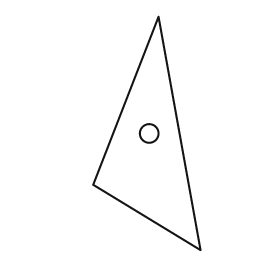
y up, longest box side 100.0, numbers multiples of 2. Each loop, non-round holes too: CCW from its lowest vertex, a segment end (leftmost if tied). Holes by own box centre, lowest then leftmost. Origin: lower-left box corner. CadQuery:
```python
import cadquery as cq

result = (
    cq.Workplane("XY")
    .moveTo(46.0, 0.0)
    .lineTo(28.0, 100.0)
    .lineTo(0.0, 28.0)
    .close()
    .moveTo(24.0, 50.0)
    .circle(4.0)
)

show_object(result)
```